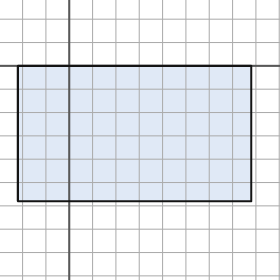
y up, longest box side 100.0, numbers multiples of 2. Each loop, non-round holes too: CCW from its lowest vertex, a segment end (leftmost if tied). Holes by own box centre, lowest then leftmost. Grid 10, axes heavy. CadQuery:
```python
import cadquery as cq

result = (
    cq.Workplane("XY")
    .moveTo(-22.0, -58.0)
    .lineTo(78.0, -58.0)
    .lineTo(78.0, 0.0)
    .lineTo(-22.0, 0.0)
    .close()
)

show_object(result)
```